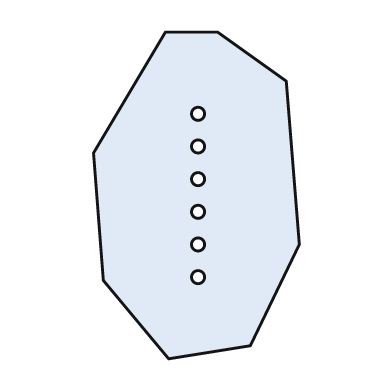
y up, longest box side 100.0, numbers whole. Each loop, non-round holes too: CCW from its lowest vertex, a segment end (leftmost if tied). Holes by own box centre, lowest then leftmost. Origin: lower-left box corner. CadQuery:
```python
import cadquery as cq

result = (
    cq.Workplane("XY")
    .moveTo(23.0, 0.0)
    .lineTo(48.0, 4.0)
    .lineTo(63.0, 35.0)
    .lineTo(59.0, 85.0)
    .lineTo(38.0, 100.0)
    .lineTo(22.0, 100.0)
    .lineTo(0.0, 63.0)
    .lineTo(3.0, 24.0)
    .close()
    .moveTo(32.0, 25.0)
    .circle(2.0)
    .moveTo(32.0, 35.0)
    .circle(2.0)
    .moveTo(32.0, 45.0)
    .circle(2.0)
    .moveTo(32.0, 55.0)
    .circle(2.0)
    .moveTo(32.0, 65.0)
    .circle(2.0)
    .moveTo(32.0, 75.0)
    .circle(2.0)
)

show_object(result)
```